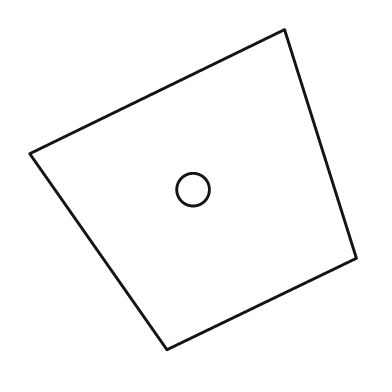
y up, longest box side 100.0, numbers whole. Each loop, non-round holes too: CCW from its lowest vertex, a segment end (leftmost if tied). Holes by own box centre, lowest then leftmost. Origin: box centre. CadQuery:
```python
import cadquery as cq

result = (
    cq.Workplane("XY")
    .moveTo(-8.0, -49.0)
    .lineTo(50.0, -21.0)
    .lineTo(28.0, 49.0)
    .lineTo(-50.0, 11.0)
    .close()
    .moveTo(0.0, 0.0)
    .circle(5.0)
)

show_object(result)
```